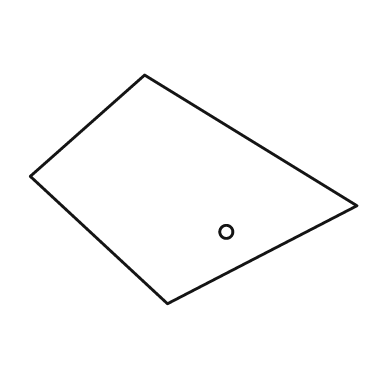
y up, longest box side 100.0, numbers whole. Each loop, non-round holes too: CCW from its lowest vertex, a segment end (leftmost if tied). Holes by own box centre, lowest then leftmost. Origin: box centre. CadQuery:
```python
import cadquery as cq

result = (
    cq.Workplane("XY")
    .moveTo(-8.0, -35.0)
    .lineTo(50.0, -5.0)
    .lineTo(-15.0, 35.0)
    .lineTo(-50.0, 4.0)
    .close()
    .moveTo(10.0, -13.0)
    .circle(2.0)
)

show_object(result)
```